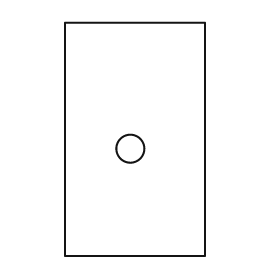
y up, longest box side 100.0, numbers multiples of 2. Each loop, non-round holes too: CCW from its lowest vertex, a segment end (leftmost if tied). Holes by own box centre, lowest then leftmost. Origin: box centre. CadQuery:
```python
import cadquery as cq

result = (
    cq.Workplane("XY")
    .moveTo(-30.0, -50.0)
    .lineTo(30.0, -50.0)
    .lineTo(30.0, 50.0)
    .lineTo(-30.0, 50.0)
    .close()
    .moveTo(-2.0, -4.0)
    .circle(6.0)
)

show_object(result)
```